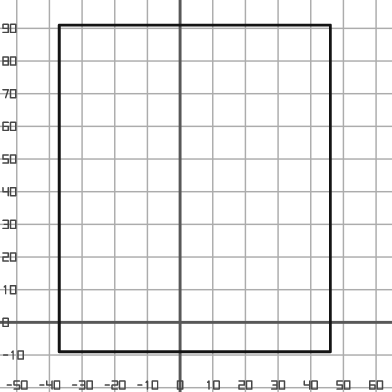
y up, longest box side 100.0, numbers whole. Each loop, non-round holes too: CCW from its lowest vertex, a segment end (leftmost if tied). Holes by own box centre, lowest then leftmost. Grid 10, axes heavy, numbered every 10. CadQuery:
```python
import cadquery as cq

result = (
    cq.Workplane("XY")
    .moveTo(-37.0, -9.0)
    .lineTo(46.0, -9.0)
    .lineTo(46.0, 91.0)
    .lineTo(-37.0, 91.0)
    .close()
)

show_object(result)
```